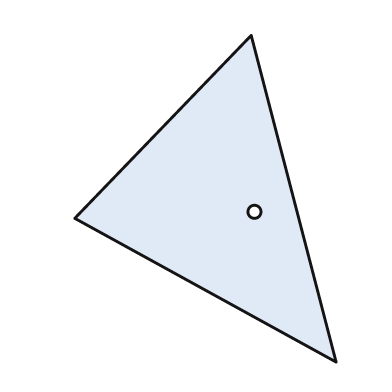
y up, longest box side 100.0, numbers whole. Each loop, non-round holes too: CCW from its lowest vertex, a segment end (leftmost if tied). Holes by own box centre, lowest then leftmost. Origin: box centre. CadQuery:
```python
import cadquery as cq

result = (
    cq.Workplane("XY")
    .moveTo(40.0, -50.0)
    .lineTo(14.0, 50.0)
    .lineTo(-40.0, -6.0)
    .close()
    .moveTo(15.0, -4.0)
    .circle(2.0)
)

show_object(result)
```